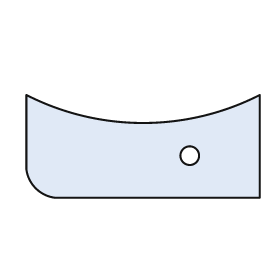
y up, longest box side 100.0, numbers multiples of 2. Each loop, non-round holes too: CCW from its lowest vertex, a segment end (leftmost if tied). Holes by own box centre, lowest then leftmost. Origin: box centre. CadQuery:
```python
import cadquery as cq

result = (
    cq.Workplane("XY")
    .moveTo(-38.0, -22.0)
    .lineTo(50.0, -22.0)
    .lineTo(50.0, 22.0)
    .threePointArc((0.0, 10.0), (-50.0, 22.0))
    .lineTo(-50.0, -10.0)
    .threePointArc((-46.0, -18.0), (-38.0, -22.0))
    .close()
    .moveTo(20.0, -4.0)
    .circle(4.0)
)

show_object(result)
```